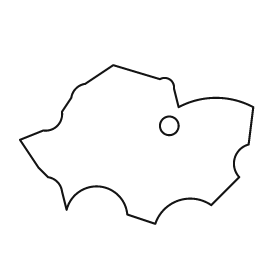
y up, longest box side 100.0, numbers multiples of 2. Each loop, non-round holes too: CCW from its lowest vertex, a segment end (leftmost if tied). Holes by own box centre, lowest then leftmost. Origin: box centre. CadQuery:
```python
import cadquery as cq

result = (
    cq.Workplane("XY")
    .moveTo(8.0, -34.0)
    .threePointArc((18.0, -24.0), (32.0, -26.0))
    .lineTo(44.0, -14.0)
    .threePointArc((42.0, -6.0), (48.0, 0.0))
    .lineTo(50.0, 16.0)
    .threePointArc((34.0, 20.0), (18.0, 16.0))
    .lineTo(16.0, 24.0)
    .threePointArc((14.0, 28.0), (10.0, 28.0))
    .lineTo(-10.0, 34.0)
    .lineTo(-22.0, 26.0)
    .threePointArc((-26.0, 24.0), (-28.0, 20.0))
    .lineTo(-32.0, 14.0)
    .threePointArc((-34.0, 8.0), (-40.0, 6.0))
    .lineTo(-50.0, 2.0)
    .lineTo(-42.0, -10.0)
    .lineTo(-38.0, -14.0)
    .threePointArc((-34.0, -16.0), (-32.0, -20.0))
    .lineTo(-30.0, -28.0)
    .threePointArc((-16.0, -18.0), (-4.0, -30.0))
    .close()
    .moveTo(14.0, 8.0)
    .circle(4.0)
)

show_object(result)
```